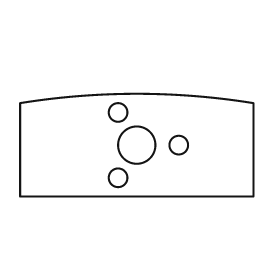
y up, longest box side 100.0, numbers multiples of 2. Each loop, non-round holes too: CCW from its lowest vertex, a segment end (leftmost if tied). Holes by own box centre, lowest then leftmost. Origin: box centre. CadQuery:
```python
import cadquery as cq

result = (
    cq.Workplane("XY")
    .moveTo(-50.0, -22.0)
    .lineTo(50.0, -22.0)
    .lineTo(50.0, 18.0)
    .threePointArc((0.0, 22.0), (-50.0, 18.0))
    .close()
    .moveTo(-8.0, -14.0)
    .circle(4.0)
    .moveTo(0.0, 0.0)
    .circle(8.0)
    .moveTo(18.0, 0.0)
    .circle(4.0)
    .moveTo(-8.0, 14.0)
    .circle(4.0)
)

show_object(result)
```